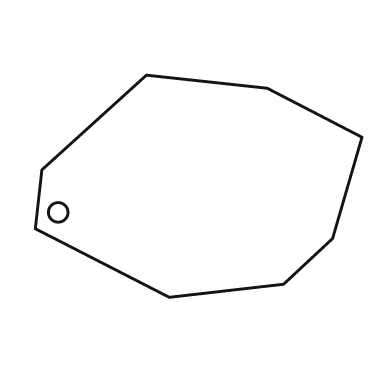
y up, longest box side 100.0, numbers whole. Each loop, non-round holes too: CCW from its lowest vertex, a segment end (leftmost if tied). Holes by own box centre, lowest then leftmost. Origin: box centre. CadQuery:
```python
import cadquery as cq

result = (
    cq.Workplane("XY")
    .moveTo(-9.0, -34.0)
    .lineTo(26.0, -30.0)
    .lineTo(41.0, -16.0)
    .lineTo(50.0, 15.0)
    .lineTo(21.0, 30.0)
    .lineTo(-16.0, 34.0)
    .lineTo(-48.0, 5.0)
    .lineTo(-50.0, -13.0)
    .close()
    .moveTo(-43.0, -8.0)
    .circle(3.0)
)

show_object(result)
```